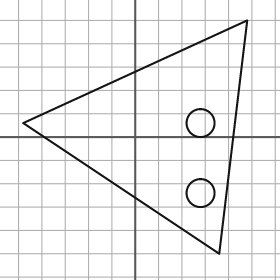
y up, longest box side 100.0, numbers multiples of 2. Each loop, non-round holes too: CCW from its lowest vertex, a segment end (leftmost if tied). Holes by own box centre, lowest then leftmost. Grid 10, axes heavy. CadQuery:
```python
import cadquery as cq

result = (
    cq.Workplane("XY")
    .moveTo(36.0, -50.0)
    .lineTo(48.0, 50.0)
    .lineTo(-48.0, 6.0)
    .close()
    .moveTo(28.0, -24.0)
    .circle(6.0)
    .moveTo(28.0, 6.0)
    .circle(6.0)
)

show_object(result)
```